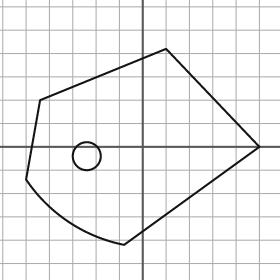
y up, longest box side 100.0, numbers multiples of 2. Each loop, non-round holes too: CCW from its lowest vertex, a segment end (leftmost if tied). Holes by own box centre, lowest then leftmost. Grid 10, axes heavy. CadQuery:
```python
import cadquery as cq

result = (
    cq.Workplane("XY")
    .moveTo(-8.0, -42.0)
    .lineTo(50.0, 0.0)
    .lineTo(10.0, 42.0)
    .lineTo(-44.0, 20.0)
    .lineTo(-50.0, -14.0)
    .threePointArc((-32.0, -32.0), (-8.0, -42.0))
    .close()
    .moveTo(-24.0, -4.0)
    .circle(6.0)
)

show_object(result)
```